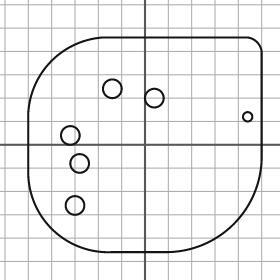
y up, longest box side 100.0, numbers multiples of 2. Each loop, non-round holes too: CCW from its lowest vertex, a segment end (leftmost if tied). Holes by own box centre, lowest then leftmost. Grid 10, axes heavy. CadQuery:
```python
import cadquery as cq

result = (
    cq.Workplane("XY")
    .moveTo(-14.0, -46.0)
    .lineTo(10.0, -46.0)
    .threePointArc((38.0, -34.0), (50.0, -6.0))
    .lineTo(50.0, 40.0)
    .threePointArc((48.0, 44.0), (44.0, 46.0))
    .lineTo(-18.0, 46.0)
    .threePointArc((-40.0, 36.0), (-50.0, 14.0))
    .lineTo(-50.0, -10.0)
    .threePointArc((-40.0, -36.0), (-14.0, -46.0))
    .close()
    .moveTo(-30.0, -26.0)
    .circle(4.0)
    .moveTo(-28.0, -8.0)
    .circle(4.0)
    .moveTo(-32.0, 4.0)
    .circle(4.0)
    .moveTo(44.0, 12.0)
    .circle(2.0)
    .moveTo(4.0, 20.0)
    .circle(4.0)
    .moveTo(-14.0, 24.0)
    .circle(4.0)
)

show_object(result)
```